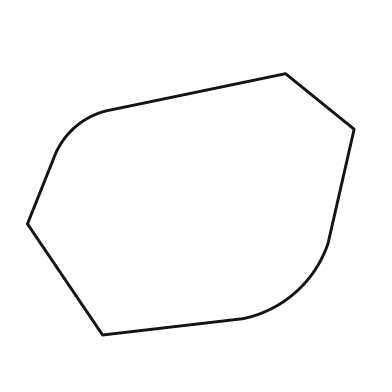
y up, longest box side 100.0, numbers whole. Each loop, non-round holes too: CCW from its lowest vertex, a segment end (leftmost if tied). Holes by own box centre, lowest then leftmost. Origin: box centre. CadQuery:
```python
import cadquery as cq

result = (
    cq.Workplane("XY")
    .moveTo(-27.0, -40.0)
    .lineTo(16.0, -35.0)
    .threePointArc((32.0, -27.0), (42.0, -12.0))
    .lineTo(50.0, 23.0)
    .lineTo(29.0, 40.0)
    .lineTo(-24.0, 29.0)
    .threePointArc((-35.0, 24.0), (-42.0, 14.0))
    .lineTo(-50.0, -6.0)
    .close()
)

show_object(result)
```